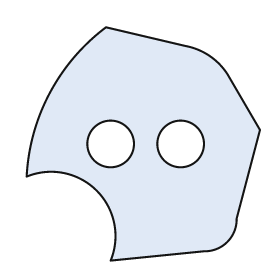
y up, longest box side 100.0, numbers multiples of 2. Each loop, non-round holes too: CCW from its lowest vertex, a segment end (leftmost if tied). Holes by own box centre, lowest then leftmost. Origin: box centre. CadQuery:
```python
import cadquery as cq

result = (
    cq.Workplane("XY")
    .moveTo(-14.0, -50.0)
    .lineTo(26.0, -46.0)
    .threePointArc((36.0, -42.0), (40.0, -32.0))
    .lineTo(50.0, 6.0)
    .lineTo(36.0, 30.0)
    .threePointArc((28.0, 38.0), (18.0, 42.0))
    .lineTo(-16.0, 50.0)
    .threePointArc((-40.0, 22.0), (-50.0, -14.0))
    .threePointArc((-20.0, -20.0), (-14.0, -50.0))
    .close()
    .moveTo(-14.0, 0.0)
    .circle(10.0)
    .moveTo(16.0, 0.0)
    .circle(10.0)
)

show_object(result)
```